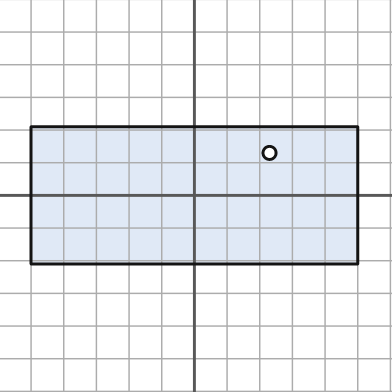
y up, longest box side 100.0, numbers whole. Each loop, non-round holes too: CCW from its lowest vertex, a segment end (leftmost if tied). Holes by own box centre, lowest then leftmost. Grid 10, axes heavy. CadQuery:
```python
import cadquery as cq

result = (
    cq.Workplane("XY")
    .moveTo(-50.0, -21.0)
    .lineTo(50.0, -21.0)
    .lineTo(50.0, 21.0)
    .lineTo(-50.0, 21.0)
    .close()
    .moveTo(23.0, 13.0)
    .circle(2.0)
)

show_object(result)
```